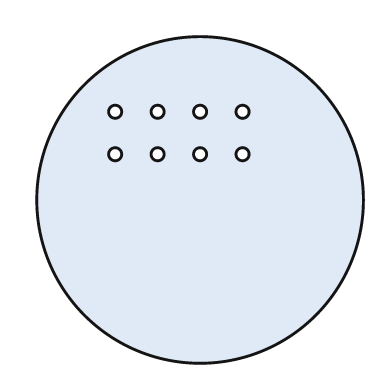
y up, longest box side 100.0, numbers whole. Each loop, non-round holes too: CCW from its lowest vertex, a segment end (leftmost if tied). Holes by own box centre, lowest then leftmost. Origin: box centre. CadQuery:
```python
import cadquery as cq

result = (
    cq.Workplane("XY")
    .moveTo(0.0, 0.0)
    .circle(50.0)
    .moveTo(-26.0, 14.0)
    .circle(2.0)
    .moveTo(-13.0, 14.0)
    .circle(2.0)
    .moveTo(0.0, 14.0)
    .circle(2.0)
    .moveTo(13.0, 14.0)
    .circle(2.0)
    .moveTo(-26.0, 27.0)
    .circle(2.0)
    .moveTo(-13.0, 27.0)
    .circle(2.0)
    .moveTo(0.0, 27.0)
    .circle(2.0)
    .moveTo(13.0, 27.0)
    .circle(2.0)
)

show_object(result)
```